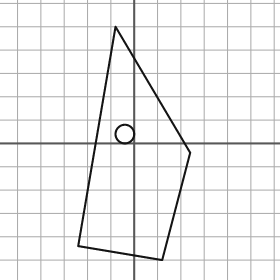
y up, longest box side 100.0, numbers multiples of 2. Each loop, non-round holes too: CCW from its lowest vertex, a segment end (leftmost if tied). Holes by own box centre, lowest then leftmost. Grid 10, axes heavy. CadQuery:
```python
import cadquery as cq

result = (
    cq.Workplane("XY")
    .moveTo(12.0, -50.0)
    .lineTo(24.0, -4.0)
    .lineTo(-8.0, 50.0)
    .lineTo(-24.0, -44.0)
    .close()
    .moveTo(-4.0, 4.0)
    .circle(4.0)
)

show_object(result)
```